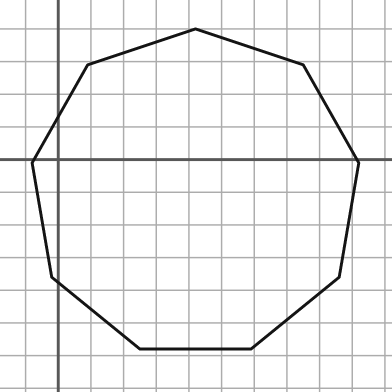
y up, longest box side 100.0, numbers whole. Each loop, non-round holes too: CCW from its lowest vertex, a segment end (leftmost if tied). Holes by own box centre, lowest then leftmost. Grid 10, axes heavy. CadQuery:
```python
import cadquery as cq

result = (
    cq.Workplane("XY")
    .moveTo(25.0, -58.0)
    .lineTo(59.0, -58.0)
    .lineTo(86.0, -36.0)
    .lineTo(92.0, -1.0)
    .lineTo(75.0, 29.0)
    .lineTo(42.0, 40.0)
    .lineTo(9.0, 29.0)
    .lineTo(-8.0, -1.0)
    .lineTo(-2.0, -36.0)
    .close()
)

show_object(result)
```